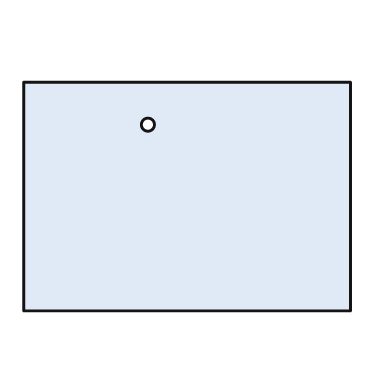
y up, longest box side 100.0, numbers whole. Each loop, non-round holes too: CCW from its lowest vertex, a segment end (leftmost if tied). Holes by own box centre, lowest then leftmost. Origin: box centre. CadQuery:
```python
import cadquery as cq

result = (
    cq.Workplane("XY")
    .moveTo(-50.0, -35.0)
    .lineTo(50.0, -35.0)
    .lineTo(50.0, 35.0)
    .lineTo(-50.0, 35.0)
    .close()
    .moveTo(-12.0, 22.0)
    .circle(2.0)
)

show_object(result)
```